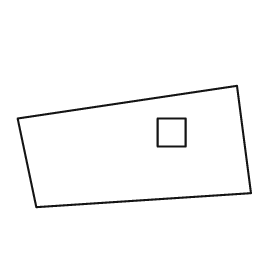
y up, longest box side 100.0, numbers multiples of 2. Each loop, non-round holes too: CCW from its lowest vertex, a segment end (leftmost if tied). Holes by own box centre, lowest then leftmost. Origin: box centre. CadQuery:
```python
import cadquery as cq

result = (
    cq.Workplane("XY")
    .moveTo(-42.0, -26.0)
    .lineTo(50.0, -20.0)
    .lineTo(44.0, 26.0)
    .lineTo(-50.0, 12.0)
    .close()
    .moveTo(10.0, 0.0)
    .lineTo(22.0, 0.0)
    .lineTo(22.0, 12.0)
    .lineTo(10.0, 12.0)
    .close()
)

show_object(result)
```